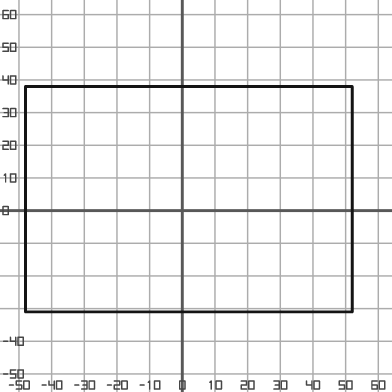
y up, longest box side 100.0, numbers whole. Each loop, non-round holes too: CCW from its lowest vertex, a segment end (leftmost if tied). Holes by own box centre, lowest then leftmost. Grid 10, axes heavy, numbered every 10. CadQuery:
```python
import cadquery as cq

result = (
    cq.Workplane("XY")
    .moveTo(-48.0, -31.0)
    .lineTo(52.0, -31.0)
    .lineTo(52.0, 38.0)
    .lineTo(-48.0, 38.0)
    .close()
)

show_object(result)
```